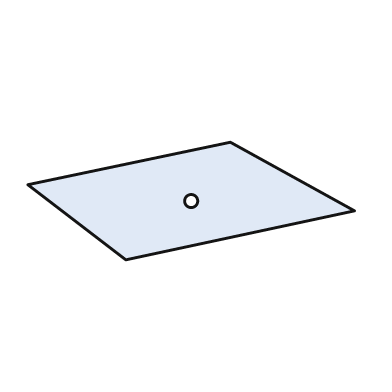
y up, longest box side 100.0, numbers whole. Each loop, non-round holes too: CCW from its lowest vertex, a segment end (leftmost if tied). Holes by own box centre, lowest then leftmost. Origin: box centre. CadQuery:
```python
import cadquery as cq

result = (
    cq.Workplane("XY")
    .moveTo(-20.0, -18.0)
    .lineTo(50.0, -3.0)
    .lineTo(12.0, 18.0)
    .lineTo(-50.0, 5.0)
    .close()
    .moveTo(0.0, 0.0)
    .circle(2.0)
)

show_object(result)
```